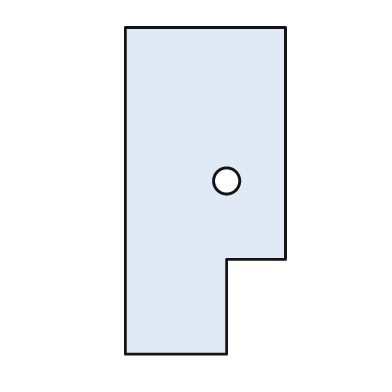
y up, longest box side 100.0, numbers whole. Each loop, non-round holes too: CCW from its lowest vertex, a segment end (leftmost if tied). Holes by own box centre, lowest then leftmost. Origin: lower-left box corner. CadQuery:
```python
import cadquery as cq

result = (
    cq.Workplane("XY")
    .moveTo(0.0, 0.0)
    .lineTo(31.0, 0.0)
    .lineTo(31.0, 29.0)
    .lineTo(49.0, 29.0)
    .lineTo(49.0, 100.0)
    .lineTo(0.0, 100.0)
    .close()
    .moveTo(31.0, 53.0)
    .circle(4.0)
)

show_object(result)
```